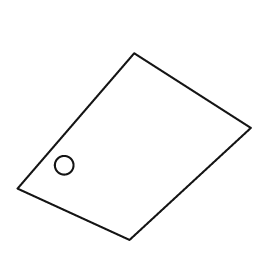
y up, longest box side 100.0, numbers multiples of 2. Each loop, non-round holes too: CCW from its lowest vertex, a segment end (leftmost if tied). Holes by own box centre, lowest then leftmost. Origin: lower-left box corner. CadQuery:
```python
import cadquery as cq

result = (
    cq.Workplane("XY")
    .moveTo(48.0, 0.0)
    .lineTo(100.0, 48.0)
    .lineTo(50.0, 80.0)
    .lineTo(0.0, 22.0)
    .close()
    .moveTo(20.0, 32.0)
    .circle(4.0)
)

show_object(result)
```